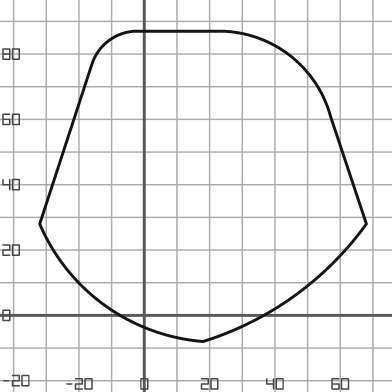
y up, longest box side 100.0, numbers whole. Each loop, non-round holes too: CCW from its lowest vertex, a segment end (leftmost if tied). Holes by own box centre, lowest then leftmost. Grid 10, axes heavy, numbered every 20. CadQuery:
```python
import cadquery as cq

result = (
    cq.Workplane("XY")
    .moveTo(18.0, -8.0)
    .threePointArc((46.0, 6.0), (68.0, 28.0))
    .lineTo(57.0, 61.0)
    .threePointArc((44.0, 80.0), (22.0, 87.0))
    .lineTo(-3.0, 87.0)
    .threePointArc((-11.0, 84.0), (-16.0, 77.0))
    .lineTo(-32.0, 28.0)
    .threePointArc((-12.0, 3.0), (18.0, -8.0))
    .close()
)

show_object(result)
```